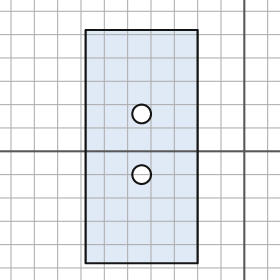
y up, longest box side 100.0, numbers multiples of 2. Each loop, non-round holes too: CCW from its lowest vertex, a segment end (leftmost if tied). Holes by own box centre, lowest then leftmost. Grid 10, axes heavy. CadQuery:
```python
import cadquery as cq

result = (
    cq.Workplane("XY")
    .moveTo(-68.0, -48.0)
    .lineTo(-20.0, -48.0)
    .lineTo(-20.0, 52.0)
    .lineTo(-68.0, 52.0)
    .close()
    .moveTo(-44.0, -10.0)
    .circle(4.0)
    .moveTo(-44.0, 16.0)
    .circle(4.0)
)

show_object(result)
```